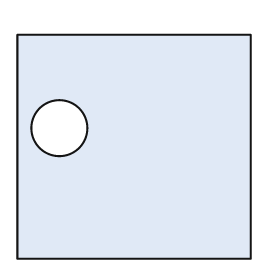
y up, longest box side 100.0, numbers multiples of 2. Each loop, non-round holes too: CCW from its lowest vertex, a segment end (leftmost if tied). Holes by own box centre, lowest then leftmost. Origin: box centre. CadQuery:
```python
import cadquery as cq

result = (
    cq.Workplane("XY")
    .moveTo(-50.0, -48.0)
    .lineTo(50.0, -48.0)
    .lineTo(50.0, 48.0)
    .lineTo(-50.0, 48.0)
    .close()
    .moveTo(-32.0, 8.0)
    .circle(12.0)
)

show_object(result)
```